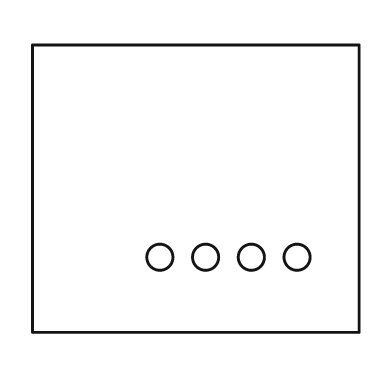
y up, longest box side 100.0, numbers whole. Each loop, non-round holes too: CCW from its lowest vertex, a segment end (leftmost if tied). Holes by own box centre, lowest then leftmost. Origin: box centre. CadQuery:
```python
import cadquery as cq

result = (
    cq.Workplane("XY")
    .moveTo(-50.0, -44.0)
    .lineTo(50.0, -44.0)
    .lineTo(50.0, 44.0)
    .lineTo(-50.0, 44.0)
    .close()
    .moveTo(-11.0, -21.0)
    .circle(4.0)
    .moveTo(3.0, -21.0)
    .circle(4.0)
    .moveTo(17.0, -21.0)
    .circle(4.0)
    .moveTo(31.0, -21.0)
    .circle(4.0)
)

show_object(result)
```